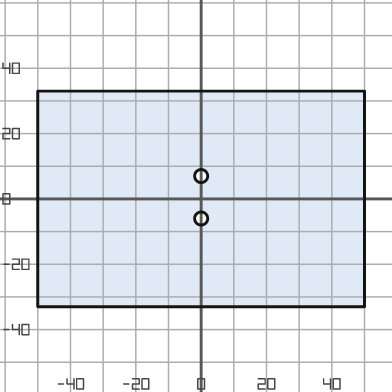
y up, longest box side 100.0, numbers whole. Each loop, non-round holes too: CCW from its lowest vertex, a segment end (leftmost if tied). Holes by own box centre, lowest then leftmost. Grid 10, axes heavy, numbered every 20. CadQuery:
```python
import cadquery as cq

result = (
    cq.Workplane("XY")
    .moveTo(-50.0, -33.0)
    .lineTo(50.0, -33.0)
    .lineTo(50.0, 33.0)
    .lineTo(-50.0, 33.0)
    .close()
    .moveTo(0.0, -6.0)
    .circle(2.0)
    .moveTo(0.0, 7.0)
    .circle(2.0)
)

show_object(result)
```